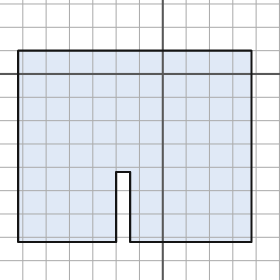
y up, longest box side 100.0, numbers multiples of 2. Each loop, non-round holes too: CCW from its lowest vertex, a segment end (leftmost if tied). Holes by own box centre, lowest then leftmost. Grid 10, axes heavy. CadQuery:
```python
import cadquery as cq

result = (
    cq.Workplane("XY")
    .moveTo(-62.0, -72.0)
    .lineTo(-20.0, -72.0)
    .lineTo(-20.0, -42.0)
    .lineTo(-14.0, -42.0)
    .lineTo(-14.0, -72.0)
    .lineTo(38.0, -72.0)
    .lineTo(38.0, 10.0)
    .lineTo(-62.0, 10.0)
    .close()
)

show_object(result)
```